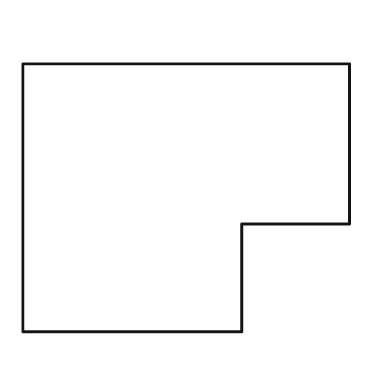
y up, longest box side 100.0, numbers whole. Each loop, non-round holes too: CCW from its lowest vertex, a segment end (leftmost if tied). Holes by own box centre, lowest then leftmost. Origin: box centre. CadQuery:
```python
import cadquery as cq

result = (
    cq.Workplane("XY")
    .moveTo(-50.0, -41.0)
    .lineTo(17.0, -41.0)
    .lineTo(17.0, -8.0)
    .lineTo(50.0, -8.0)
    .lineTo(50.0, 41.0)
    .lineTo(-50.0, 41.0)
    .close()
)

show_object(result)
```